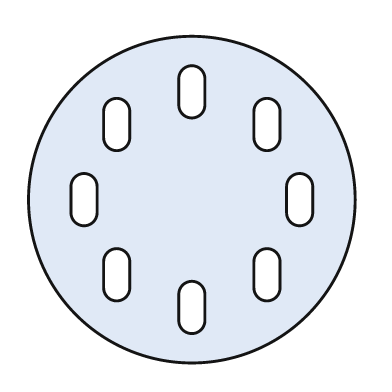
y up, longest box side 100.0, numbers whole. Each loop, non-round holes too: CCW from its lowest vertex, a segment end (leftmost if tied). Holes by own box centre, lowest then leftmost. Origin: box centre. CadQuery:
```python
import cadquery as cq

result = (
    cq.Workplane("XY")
    .moveTo(0.0, 0.0)
    .circle(50.0)
    .moveTo(-4.0, -37.0)
    .threePointArc((0.0, -41.0), (4.0, -37.0))
    .lineTo(4.0, -29.0)
    .threePointArc((0.0, -25.0), (-4.0, -29.0))
    .close()
    .moveTo(-27.0, -27.0)
    .threePointArc((-23.0, -31.0), (-19.0, -27.0))
    .lineTo(-19.0, -19.0)
    .threePointArc((-23.0, -15.0), (-27.0, -19.0))
    .close()
    .moveTo(19.0, -27.0)
    .threePointArc((23.0, -31.0), (27.0, -27.0))
    .lineTo(27.0, -19.0)
    .threePointArc((23.0, -15.0), (19.0, -19.0))
    .close()
    .moveTo(-37.0, -4.0)
    .threePointArc((-33.0, -8.0), (-29.0, -4.0))
    .lineTo(-29.0, 4.0)
    .threePointArc((-33.0, 8.0), (-37.0, 4.0))
    .close()
    .moveTo(29.0, -4.0)
    .threePointArc((33.0, -8.0), (37.0, -4.0))
    .lineTo(37.0, 4.0)
    .threePointArc((33.0, 8.0), (29.0, 4.0))
    .close()
    .moveTo(-27.0, 19.0)
    .threePointArc((-23.0, 15.0), (-19.0, 19.0))
    .lineTo(-19.0, 27.0)
    .threePointArc((-23.0, 31.0), (-27.0, 27.0))
    .close()
    .moveTo(19.0, 19.0)
    .threePointArc((23.0, 15.0), (27.0, 19.0))
    .lineTo(27.0, 27.0)
    .threePointArc((23.0, 31.0), (19.0, 27.0))
    .close()
    .moveTo(-4.0, 29.0)
    .threePointArc((0.0, 25.0), (4.0, 29.0))
    .lineTo(4.0, 37.0)
    .threePointArc((0.0, 41.0), (-4.0, 37.0))
    .close()
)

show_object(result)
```